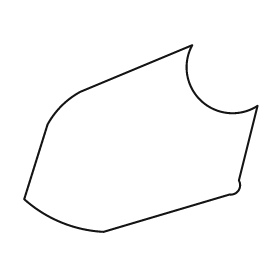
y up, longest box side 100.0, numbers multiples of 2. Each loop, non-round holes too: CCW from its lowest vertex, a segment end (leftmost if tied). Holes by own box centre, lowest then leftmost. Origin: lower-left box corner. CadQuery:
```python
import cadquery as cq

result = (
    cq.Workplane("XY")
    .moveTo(34.0, 0.0)
    .lineTo(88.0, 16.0)
    .threePointArc((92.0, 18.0), (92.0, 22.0))
    .lineTo(100.0, 54.0)
    .threePointArc((76.0, 56.0), (72.0, 80.0))
    .lineTo(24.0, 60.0)
    .threePointArc((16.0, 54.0), (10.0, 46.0))
    .lineTo(0.0, 14.0)
    .threePointArc((16.0, 4.0), (34.0, 0.0))
    .close()
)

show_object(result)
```